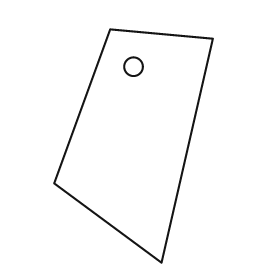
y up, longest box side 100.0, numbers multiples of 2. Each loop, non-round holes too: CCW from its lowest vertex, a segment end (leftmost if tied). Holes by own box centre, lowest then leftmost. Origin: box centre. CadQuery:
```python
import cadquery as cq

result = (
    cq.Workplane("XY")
    .moveTo(12.0, -50.0)
    .lineTo(34.0, 46.0)
    .lineTo(-10.0, 50.0)
    .lineTo(-34.0, -16.0)
    .close()
    .moveTo(0.0, 34.0)
    .circle(4.0)
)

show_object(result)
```